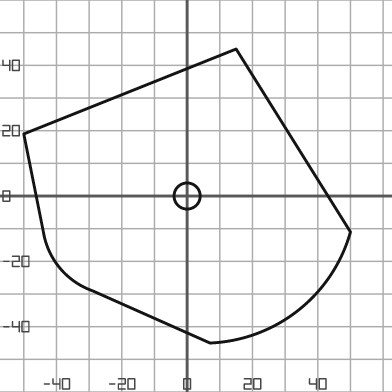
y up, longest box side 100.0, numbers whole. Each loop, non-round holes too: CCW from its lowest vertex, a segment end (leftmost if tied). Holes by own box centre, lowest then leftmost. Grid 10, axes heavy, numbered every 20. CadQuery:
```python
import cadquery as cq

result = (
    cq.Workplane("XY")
    .moveTo(7.0, -45.0)
    .threePointArc((34.0, -35.0), (50.0, -11.0))
    .lineTo(15.0, 45.0)
    .lineTo(-50.0, 19.0)
    .lineTo(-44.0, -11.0)
    .threePointArc((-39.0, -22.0), (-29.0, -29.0))
    .close()
    .moveTo(0.0, 0.0)
    .circle(4.0)
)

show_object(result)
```